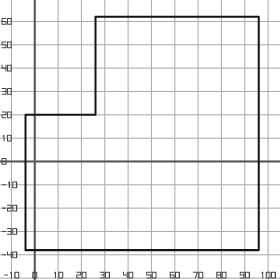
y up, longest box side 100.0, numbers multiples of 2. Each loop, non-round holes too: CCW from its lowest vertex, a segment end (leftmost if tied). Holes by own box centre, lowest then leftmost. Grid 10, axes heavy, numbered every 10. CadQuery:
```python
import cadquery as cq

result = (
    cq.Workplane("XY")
    .moveTo(-4.0, -38.0)
    .lineTo(96.0, -38.0)
    .lineTo(96.0, 62.0)
    .lineTo(26.0, 62.0)
    .lineTo(26.0, 20.0)
    .lineTo(-4.0, 20.0)
    .close()
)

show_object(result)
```